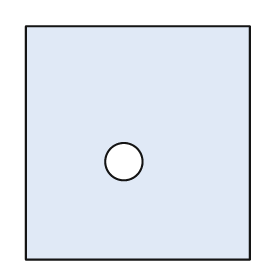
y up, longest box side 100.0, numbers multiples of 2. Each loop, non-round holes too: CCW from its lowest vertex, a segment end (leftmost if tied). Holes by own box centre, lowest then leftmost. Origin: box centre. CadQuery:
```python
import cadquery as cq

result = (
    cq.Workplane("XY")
    .moveTo(-48.0, -50.0)
    .lineTo(48.0, -50.0)
    .lineTo(48.0, 50.0)
    .lineTo(-48.0, 50.0)
    .close()
    .moveTo(-6.0, -8.0)
    .circle(8.0)
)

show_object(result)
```